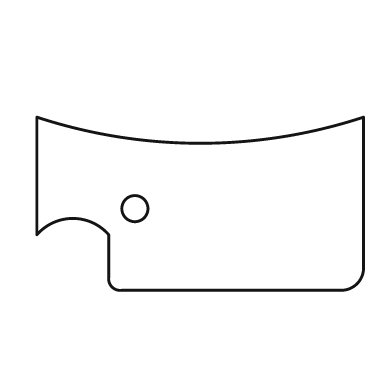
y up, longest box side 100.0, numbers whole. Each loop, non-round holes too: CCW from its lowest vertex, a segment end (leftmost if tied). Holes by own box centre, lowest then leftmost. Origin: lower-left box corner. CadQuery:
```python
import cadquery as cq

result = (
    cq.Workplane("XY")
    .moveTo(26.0, 0.0)
    .lineTo(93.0, 0.0)
    .threePointArc((98.0, 2.0), (100.0, 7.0))
    .lineTo(100.0, 53.0)
    .threePointArc((50.0, 45.0), (0.0, 53.0))
    .lineTo(0.0, 17.0)
    .threePointArc((11.0, 22.0), (22.0, 17.0))
    .lineTo(22.0, 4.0)
    .threePointArc((23.0, 1.0), (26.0, 0.0))
    .close()
    .moveTo(30.0, 25.0)
    .circle(4.0)
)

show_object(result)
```